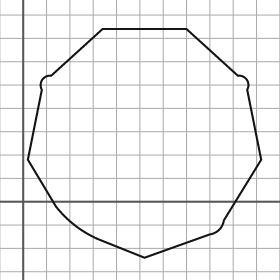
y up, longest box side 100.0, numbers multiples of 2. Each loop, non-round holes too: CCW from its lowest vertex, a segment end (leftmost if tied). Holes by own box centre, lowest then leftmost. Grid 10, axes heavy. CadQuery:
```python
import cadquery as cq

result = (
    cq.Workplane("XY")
    .moveTo(52.0, -24.0)
    .lineTo(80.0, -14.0)
    .threePointArc((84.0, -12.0), (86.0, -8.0))
    .lineTo(102.0, 18.0)
    .lineTo(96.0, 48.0)
    .threePointArc((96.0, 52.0), (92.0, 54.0))
    .lineTo(70.0, 74.0)
    .lineTo(34.0, 74.0)
    .lineTo(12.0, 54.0)
    .threePointArc((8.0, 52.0), (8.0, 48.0))
    .lineTo(2.0, 18.0)
    .lineTo(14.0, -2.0)
    .threePointArc((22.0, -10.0), (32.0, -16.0))
    .close()
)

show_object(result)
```